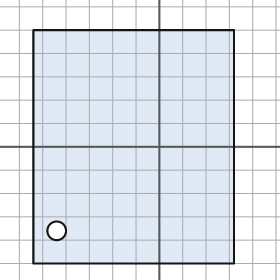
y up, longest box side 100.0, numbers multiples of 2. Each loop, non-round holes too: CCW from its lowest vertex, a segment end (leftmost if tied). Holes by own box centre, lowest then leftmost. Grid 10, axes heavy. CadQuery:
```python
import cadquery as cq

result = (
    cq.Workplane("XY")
    .moveTo(-54.0, -50.0)
    .lineTo(32.0, -50.0)
    .lineTo(32.0, 50.0)
    .lineTo(-54.0, 50.0)
    .close()
    .moveTo(-44.0, -36.0)
    .circle(4.0)
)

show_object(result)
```